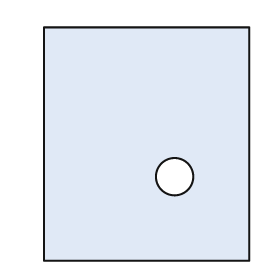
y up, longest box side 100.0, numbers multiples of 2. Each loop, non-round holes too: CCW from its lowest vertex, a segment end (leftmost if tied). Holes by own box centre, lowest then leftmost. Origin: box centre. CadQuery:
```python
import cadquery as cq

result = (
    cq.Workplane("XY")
    .moveTo(-44.0, -50.0)
    .lineTo(44.0, -50.0)
    .lineTo(44.0, 50.0)
    .lineTo(-44.0, 50.0)
    .close()
    .moveTo(12.0, -14.0)
    .circle(8.0)
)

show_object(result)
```